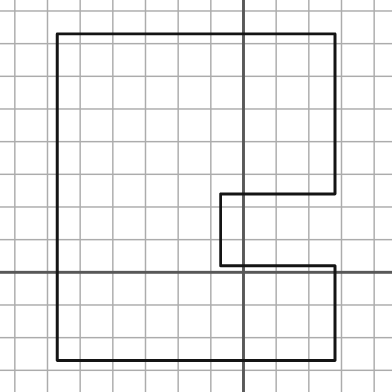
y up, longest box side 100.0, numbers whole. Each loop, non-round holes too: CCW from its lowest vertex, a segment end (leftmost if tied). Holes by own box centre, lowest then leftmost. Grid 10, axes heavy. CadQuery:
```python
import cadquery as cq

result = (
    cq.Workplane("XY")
    .moveTo(-57.0, -27.0)
    .lineTo(28.0, -27.0)
    .lineTo(28.0, 2.0)
    .lineTo(-7.0, 2.0)
    .lineTo(-7.0, 24.0)
    .lineTo(28.0, 24.0)
    .lineTo(28.0, 73.0)
    .lineTo(-57.0, 73.0)
    .close()
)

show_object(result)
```